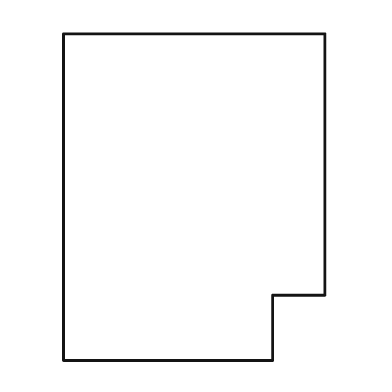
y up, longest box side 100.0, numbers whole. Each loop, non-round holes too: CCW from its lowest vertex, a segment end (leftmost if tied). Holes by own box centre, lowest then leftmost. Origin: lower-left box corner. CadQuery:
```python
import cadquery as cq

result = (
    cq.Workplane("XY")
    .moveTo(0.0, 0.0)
    .lineTo(64.0, 0.0)
    .lineTo(64.0, 20.0)
    .lineTo(80.0, 20.0)
    .lineTo(80.0, 100.0)
    .lineTo(0.0, 100.0)
    .close()
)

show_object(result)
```